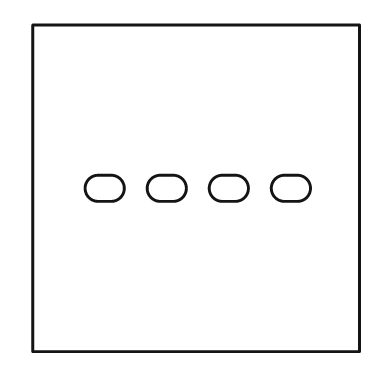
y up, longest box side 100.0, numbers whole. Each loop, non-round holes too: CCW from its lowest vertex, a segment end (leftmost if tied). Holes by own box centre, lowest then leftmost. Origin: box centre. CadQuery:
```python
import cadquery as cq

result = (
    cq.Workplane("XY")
    .moveTo(-50.0, -50.0)
    .lineTo(50.0, -50.0)
    .lineTo(50.0, 50.0)
    .lineTo(-50.0, 50.0)
    .close()
    .moveTo(-30.0, -4.0)
    .lineTo(-26.0, -4.0)
    .threePointArc((-22.0, 0.0), (-26.0, 4.0))
    .lineTo(-30.0, 4.0)
    .threePointArc((-34.0, 0.0), (-30.0, -4.0))
    .close()
    .moveTo(-11.0, -4.0)
    .lineTo(-7.0, -4.0)
    .threePointArc((-3.0, 0.0), (-7.0, 4.0))
    .lineTo(-11.0, 4.0)
    .threePointArc((-15.0, 0.0), (-11.0, -4.0))
    .close()
    .moveTo(8.0, -4.0)
    .lineTo(12.0, -4.0)
    .threePointArc((16.0, 0.0), (12.0, 4.0))
    .lineTo(8.0, 4.0)
    .threePointArc((4.0, 0.0), (8.0, -4.0))
    .close()
    .moveTo(27.0, -4.0)
    .lineTo(31.0, -4.0)
    .threePointArc((35.0, 0.0), (31.0, 4.0))
    .lineTo(27.0, 4.0)
    .threePointArc((23.0, 0.0), (27.0, -4.0))
    .close()
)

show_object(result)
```